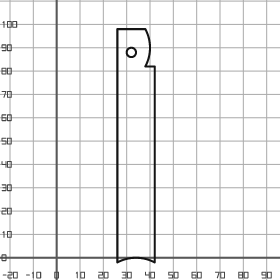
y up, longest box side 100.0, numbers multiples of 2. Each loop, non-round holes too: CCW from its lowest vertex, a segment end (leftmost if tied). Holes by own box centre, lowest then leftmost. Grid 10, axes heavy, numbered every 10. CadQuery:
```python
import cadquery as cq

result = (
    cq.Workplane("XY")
    .moveTo(26.0, -2.0)
    .threePointArc((34.0, 0.0), (42.0, -2.0))
    .lineTo(42.0, 82.0)
    .lineTo(38.0, 82.0)
    .threePointArc((40.0, 90.0), (38.0, 98.0))
    .lineTo(26.0, 98.0)
    .close()
    .moveTo(32.0, 88.0)
    .circle(2.0)
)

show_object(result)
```